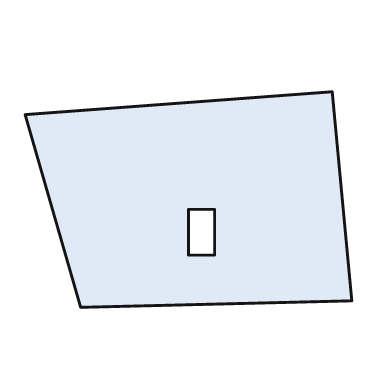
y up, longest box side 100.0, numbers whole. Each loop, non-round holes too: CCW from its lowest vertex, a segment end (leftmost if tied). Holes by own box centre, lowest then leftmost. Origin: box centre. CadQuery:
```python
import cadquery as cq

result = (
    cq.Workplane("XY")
    .moveTo(-33.0, -33.0)
    .lineTo(50.0, -31.0)
    .lineTo(44.0, 33.0)
    .lineTo(-50.0, 26.0)
    .close()
    .moveTo(0.0, -17.0)
    .lineTo(8.0, -17.0)
    .lineTo(8.0, -3.0)
    .lineTo(0.0, -3.0)
    .close()
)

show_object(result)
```